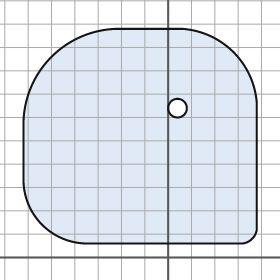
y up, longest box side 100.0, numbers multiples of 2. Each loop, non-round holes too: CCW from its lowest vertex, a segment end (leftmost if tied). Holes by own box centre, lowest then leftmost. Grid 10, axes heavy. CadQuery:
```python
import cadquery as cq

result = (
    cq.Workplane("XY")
    .moveTo(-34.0, 6.0)
    .lineTo(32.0, 6.0)
    .threePointArc((36.0, 8.0), (38.0, 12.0))
    .lineTo(38.0, 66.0)
    .threePointArc((28.0, 88.0), (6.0, 98.0))
    .lineTo(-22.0, 98.0)
    .threePointArc((-50.0, 86.0), (-62.0, 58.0))
    .lineTo(-62.0, 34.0)
    .threePointArc((-54.0, 14.0), (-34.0, 6.0))
    .close()
    .moveTo(4.0, 64.0)
    .circle(4.0)
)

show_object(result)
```